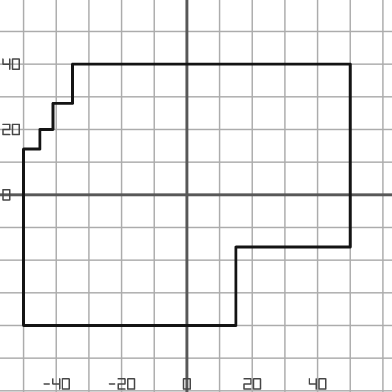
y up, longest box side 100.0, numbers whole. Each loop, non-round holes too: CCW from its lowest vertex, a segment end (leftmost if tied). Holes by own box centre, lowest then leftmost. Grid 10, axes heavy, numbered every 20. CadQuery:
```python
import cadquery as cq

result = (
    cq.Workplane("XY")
    .moveTo(-50.0, -40.0)
    .lineTo(15.0, -40.0)
    .lineTo(15.0, -16.0)
    .lineTo(50.0, -16.0)
    .lineTo(50.0, 40.0)
    .lineTo(-35.0, 40.0)
    .lineTo(-35.0, 28.0)
    .lineTo(-41.0, 28.0)
    .lineTo(-41.0, 20.0)
    .lineTo(-45.0, 20.0)
    .lineTo(-45.0, 14.0)
    .lineTo(-50.0, 14.0)
    .close()
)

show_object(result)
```